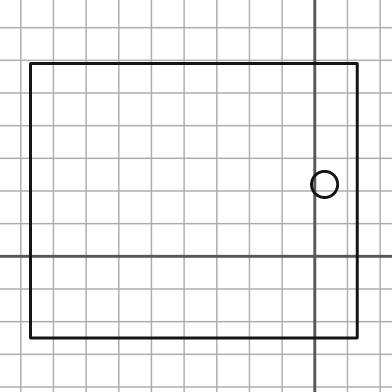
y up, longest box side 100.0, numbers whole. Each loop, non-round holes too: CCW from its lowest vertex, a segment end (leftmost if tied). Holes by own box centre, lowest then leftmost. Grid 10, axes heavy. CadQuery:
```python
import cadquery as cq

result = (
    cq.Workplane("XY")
    .moveTo(-87.0, -25.0)
    .lineTo(13.0, -25.0)
    .lineTo(13.0, 59.0)
    .lineTo(-87.0, 59.0)
    .close()
    .moveTo(3.0, 22.0)
    .circle(4.0)
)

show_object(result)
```